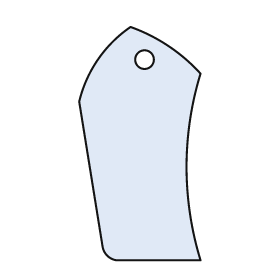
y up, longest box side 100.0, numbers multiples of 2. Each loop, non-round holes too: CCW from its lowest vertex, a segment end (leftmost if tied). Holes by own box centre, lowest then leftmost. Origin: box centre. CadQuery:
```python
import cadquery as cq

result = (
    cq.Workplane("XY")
    .moveTo(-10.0, -50.0)
    .lineTo(26.0, -50.0)
    .threePointArc((20.0, -10.0), (26.0, 30.0))
    .threePointArc((12.0, 42.0), (-4.0, 50.0))
    .threePointArc((-18.0, 36.0), (-26.0, 18.0))
    .lineTo(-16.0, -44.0)
    .threePointArc((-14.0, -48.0), (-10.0, -50.0))
    .close()
    .moveTo(2.0, 36.0)
    .circle(4.0)
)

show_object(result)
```